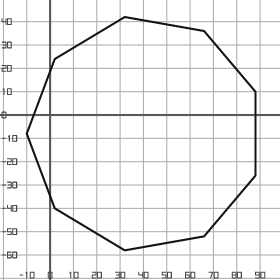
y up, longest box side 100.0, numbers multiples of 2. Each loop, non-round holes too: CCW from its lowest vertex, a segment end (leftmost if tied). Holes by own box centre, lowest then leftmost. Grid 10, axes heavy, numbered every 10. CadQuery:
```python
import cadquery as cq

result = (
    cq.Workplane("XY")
    .moveTo(32.0, -58.0)
    .lineTo(66.0, -52.0)
    .lineTo(88.0, -26.0)
    .lineTo(88.0, 10.0)
    .lineTo(66.0, 36.0)
    .lineTo(32.0, 42.0)
    .lineTo(2.0, 24.0)
    .lineTo(-10.0, -8.0)
    .lineTo(2.0, -40.0)
    .close()
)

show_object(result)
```